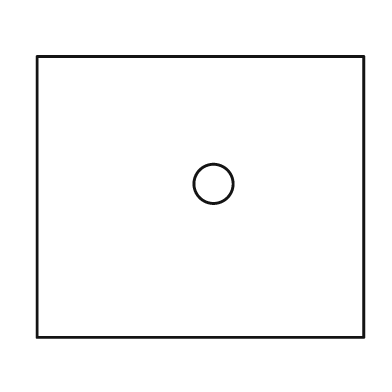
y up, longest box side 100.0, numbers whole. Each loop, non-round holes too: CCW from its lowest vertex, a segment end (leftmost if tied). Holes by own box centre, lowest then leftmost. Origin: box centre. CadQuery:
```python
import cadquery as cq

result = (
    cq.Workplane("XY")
    .moveTo(-50.0, -43.0)
    .lineTo(50.0, -43.0)
    .lineTo(50.0, 43.0)
    .lineTo(-50.0, 43.0)
    .close()
    .moveTo(4.0, 4.0)
    .circle(6.0)
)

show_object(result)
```